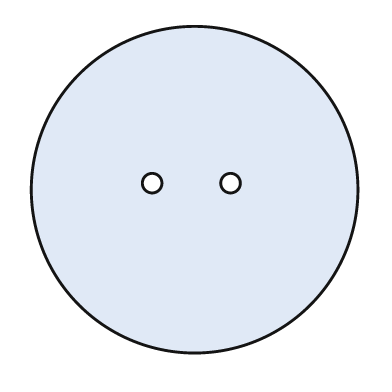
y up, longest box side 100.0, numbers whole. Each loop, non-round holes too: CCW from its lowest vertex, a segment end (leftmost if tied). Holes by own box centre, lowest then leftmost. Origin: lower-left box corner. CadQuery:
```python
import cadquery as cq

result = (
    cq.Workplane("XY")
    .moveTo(50.0, 50.0)
    .circle(50.0)
    .moveTo(37.0, 52.0)
    .circle(3.0)
    .moveTo(61.0, 52.0)
    .circle(3.0)
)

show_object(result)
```